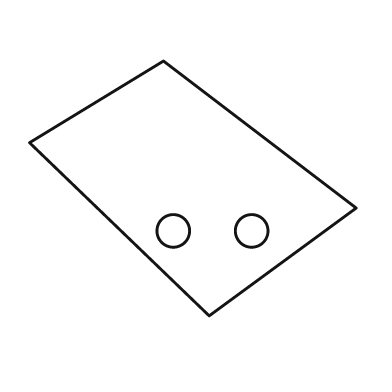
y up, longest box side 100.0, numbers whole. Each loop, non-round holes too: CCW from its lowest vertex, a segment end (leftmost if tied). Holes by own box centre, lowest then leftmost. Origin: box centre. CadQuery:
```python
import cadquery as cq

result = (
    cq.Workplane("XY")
    .moveTo(5.0, -39.0)
    .lineTo(50.0, -6.0)
    .lineTo(-9.0, 39.0)
    .lineTo(-50.0, 14.0)
    .close()
    .moveTo(-6.0, -13.0)
    .circle(5.0)
    .moveTo(18.0, -13.0)
    .circle(5.0)
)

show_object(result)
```